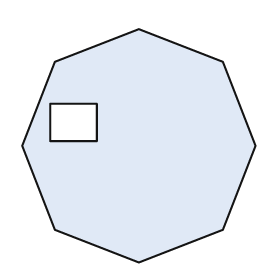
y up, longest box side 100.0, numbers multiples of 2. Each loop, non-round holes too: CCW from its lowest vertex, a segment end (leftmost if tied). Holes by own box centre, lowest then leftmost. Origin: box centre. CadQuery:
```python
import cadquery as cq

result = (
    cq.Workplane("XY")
    .moveTo(0.0, -50.0)
    .lineTo(36.0, -36.0)
    .lineTo(50.0, 0.0)
    .lineTo(36.0, 36.0)
    .lineTo(0.0, 50.0)
    .lineTo(-36.0, 36.0)
    .lineTo(-50.0, 0.0)
    .lineTo(-36.0, -36.0)
    .close()
    .moveTo(-38.0, 2.0)
    .lineTo(-18.0, 2.0)
    .lineTo(-18.0, 18.0)
    .lineTo(-38.0, 18.0)
    .close()
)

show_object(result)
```